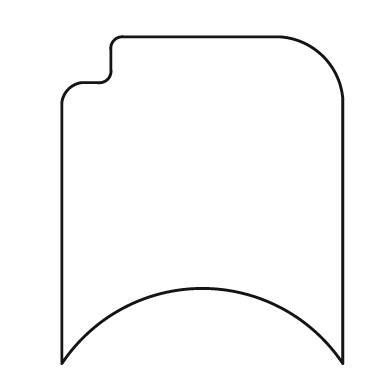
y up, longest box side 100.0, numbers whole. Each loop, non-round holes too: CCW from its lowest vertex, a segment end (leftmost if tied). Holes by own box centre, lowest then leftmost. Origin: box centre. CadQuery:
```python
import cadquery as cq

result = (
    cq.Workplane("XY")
    .moveTo(-43.0, -50.0)
    .threePointArc((0.0, -27.0), (43.0, -50.0))
    .lineTo(43.0, 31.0)
    .threePointArc((37.0, 44.0), (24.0, 50.0))
    .lineTo(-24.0, 50.0)
    .threePointArc((-27.0, 49.0), (-28.0, 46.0))
    .lineTo(-28.0, 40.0)
    .threePointArc((-29.0, 37.0), (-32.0, 36.0))
    .lineTo(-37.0, 36.0)
    .threePointArc((-41.0, 34.0), (-43.0, 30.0))
    .close()
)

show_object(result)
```